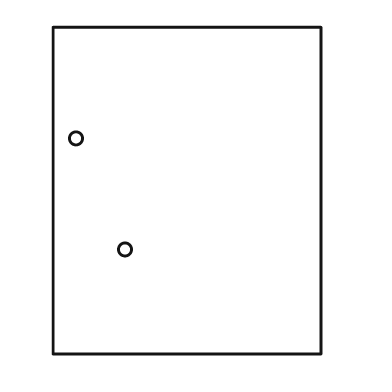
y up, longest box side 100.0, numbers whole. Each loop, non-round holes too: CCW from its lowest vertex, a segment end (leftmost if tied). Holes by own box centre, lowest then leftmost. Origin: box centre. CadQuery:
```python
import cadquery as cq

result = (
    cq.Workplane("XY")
    .moveTo(-41.0, -50.0)
    .lineTo(41.0, -50.0)
    .lineTo(41.0, 50.0)
    .lineTo(-41.0, 50.0)
    .close()
    .moveTo(-19.0, -18.0)
    .circle(2.0)
    .moveTo(-34.0, 16.0)
    .circle(2.0)
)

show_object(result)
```